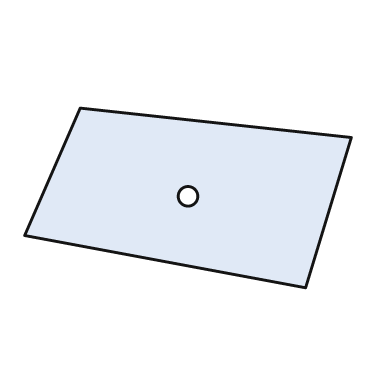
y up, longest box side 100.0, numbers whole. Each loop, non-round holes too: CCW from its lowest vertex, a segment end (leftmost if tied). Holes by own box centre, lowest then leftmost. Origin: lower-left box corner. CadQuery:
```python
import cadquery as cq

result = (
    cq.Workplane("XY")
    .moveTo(86.0, 0.0)
    .lineTo(100.0, 46.0)
    .lineTo(17.0, 55.0)
    .lineTo(0.0, 16.0)
    .close()
    .moveTo(50.0, 28.0)
    .circle(3.0)
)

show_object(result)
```